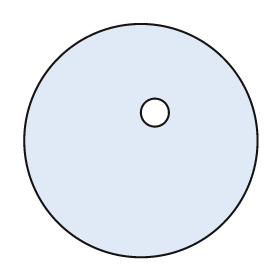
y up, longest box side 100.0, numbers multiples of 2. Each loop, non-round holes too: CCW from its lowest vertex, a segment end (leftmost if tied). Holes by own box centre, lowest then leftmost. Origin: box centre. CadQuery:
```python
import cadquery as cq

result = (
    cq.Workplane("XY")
    .moveTo(0.0, 0.0)
    .circle(50.0)
    .moveTo(6.0, 12.0)
    .circle(6.0)
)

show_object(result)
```